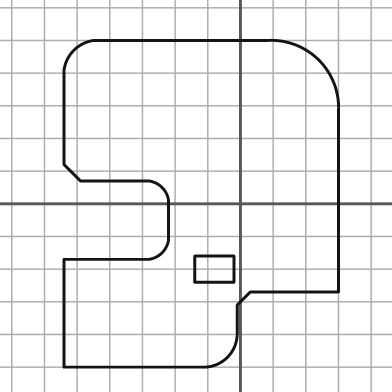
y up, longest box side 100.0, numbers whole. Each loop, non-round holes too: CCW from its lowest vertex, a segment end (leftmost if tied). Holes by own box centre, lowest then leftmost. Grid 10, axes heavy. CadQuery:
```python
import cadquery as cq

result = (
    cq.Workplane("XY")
    .moveTo(-54.0, -50.0)
    .lineTo(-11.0, -50.0)
    .threePointArc((-4.0, -47.0), (-1.0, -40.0))
    .lineTo(-1.0, -31.0)
    .lineTo(3.0, -27.0)
    .lineTo(30.0, -27.0)
    .lineTo(30.0, 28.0)
    .threePointArc((24.0, 44.0), (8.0, 50.0))
    .lineTo(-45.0, 50.0)
    .threePointArc((-51.0, 47.0), (-54.0, 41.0))
    .lineTo(-54.0, 12.0)
    .lineTo(-49.0, 7.0)
    .lineTo(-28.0, 7.0)
    .threePointArc((-24.0, 5.0), (-22.0, 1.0))
    .lineTo(-22.0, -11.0)
    .threePointArc((-24.0, -15.0), (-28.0, -17.0))
    .lineTo(-54.0, -17.0)
    .close()
    .moveTo(-14.0, -24.0)
    .lineTo(-2.0, -24.0)
    .lineTo(-2.0, -16.0)
    .lineTo(-14.0, -16.0)
    .close()
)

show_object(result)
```